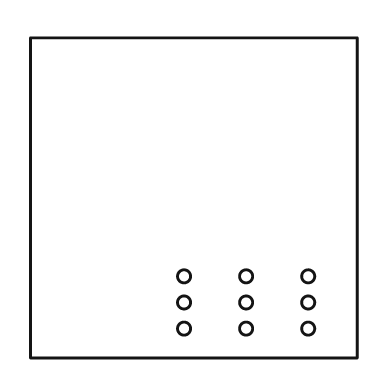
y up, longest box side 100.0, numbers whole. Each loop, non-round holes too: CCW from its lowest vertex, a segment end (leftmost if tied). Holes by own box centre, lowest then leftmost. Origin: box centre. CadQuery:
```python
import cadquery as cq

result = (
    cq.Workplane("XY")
    .moveTo(-50.0, -49.0)
    .lineTo(50.0, -49.0)
    .lineTo(50.0, 49.0)
    .lineTo(-50.0, 49.0)
    .close()
    .moveTo(-3.0, -40.0)
    .circle(2.0)
    .moveTo(16.0, -40.0)
    .circle(2.0)
    .moveTo(35.0, -40.0)
    .circle(2.0)
    .moveTo(-3.0, -32.0)
    .circle(2.0)
    .moveTo(16.0, -32.0)
    .circle(2.0)
    .moveTo(35.0, -32.0)
    .circle(2.0)
    .moveTo(-3.0, -24.0)
    .circle(2.0)
    .moveTo(16.0, -24.0)
    .circle(2.0)
    .moveTo(35.0, -24.0)
    .circle(2.0)
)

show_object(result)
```